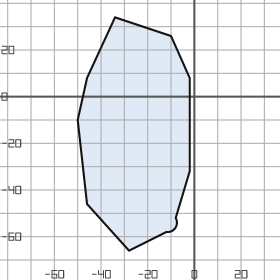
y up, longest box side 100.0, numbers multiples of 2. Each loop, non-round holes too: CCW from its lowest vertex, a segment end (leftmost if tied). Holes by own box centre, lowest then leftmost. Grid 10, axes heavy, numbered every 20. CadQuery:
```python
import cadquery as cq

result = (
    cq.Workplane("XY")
    .moveTo(-28.0, -66.0)
    .lineTo(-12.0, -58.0)
    .threePointArc((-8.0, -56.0), (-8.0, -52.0))
    .lineTo(-2.0, -32.0)
    .lineTo(-2.0, 8.0)
    .lineTo(-10.0, 26.0)
    .lineTo(-34.0, 34.0)
    .lineTo(-46.0, 8.0)
    .lineTo(-50.0, -10.0)
    .lineTo(-46.0, -46.0)
    .close()
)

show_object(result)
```